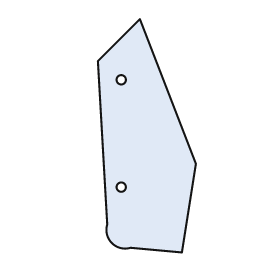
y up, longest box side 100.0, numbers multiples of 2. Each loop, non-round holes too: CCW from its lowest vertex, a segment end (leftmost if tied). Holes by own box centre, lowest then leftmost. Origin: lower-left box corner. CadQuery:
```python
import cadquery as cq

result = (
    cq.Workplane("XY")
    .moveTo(36.0, 0.0)
    .lineTo(42.0, 38.0)
    .lineTo(18.0, 100.0)
    .lineTo(0.0, 82.0)
    .lineTo(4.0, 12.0)
    .threePointArc((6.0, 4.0), (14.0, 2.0))
    .close()
    .moveTo(10.0, 28.0)
    .circle(2.0)
    .moveTo(10.0, 74.0)
    .circle(2.0)
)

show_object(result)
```